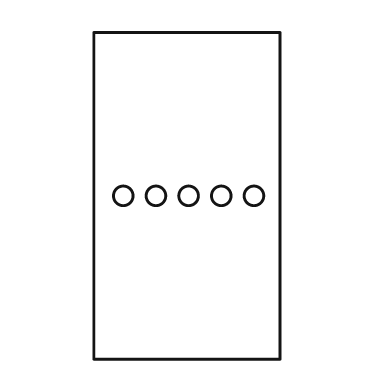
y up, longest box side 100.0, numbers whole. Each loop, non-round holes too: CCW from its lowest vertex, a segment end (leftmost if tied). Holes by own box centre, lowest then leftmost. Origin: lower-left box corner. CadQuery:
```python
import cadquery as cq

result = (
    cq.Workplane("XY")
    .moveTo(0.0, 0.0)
    .lineTo(57.0, 0.0)
    .lineTo(57.0, 100.0)
    .lineTo(0.0, 100.0)
    .close()
    .moveTo(9.0, 50.0)
    .circle(3.0)
    .moveTo(19.0, 50.0)
    .circle(3.0)
    .moveTo(29.0, 50.0)
    .circle(3.0)
    .moveTo(39.0, 50.0)
    .circle(3.0)
    .moveTo(49.0, 50.0)
    .circle(3.0)
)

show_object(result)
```